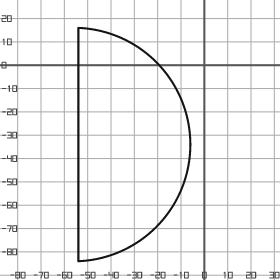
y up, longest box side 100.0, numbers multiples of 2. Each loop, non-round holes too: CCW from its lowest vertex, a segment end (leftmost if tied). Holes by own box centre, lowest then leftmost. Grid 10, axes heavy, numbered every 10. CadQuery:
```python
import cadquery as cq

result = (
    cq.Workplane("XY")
    .moveTo(-54.0, -84.0)
    .threePointArc((-6.0, -34.0), (-54.0, 16.0))
    .close()
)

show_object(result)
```